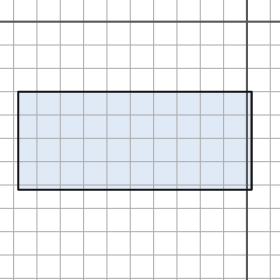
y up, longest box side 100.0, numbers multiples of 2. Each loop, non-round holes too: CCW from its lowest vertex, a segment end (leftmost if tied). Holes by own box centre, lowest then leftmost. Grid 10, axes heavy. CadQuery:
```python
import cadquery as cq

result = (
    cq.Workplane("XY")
    .moveTo(-98.0, -72.0)
    .lineTo(2.0, -72.0)
    .lineTo(2.0, -30.0)
    .lineTo(-98.0, -30.0)
    .close()
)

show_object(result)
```